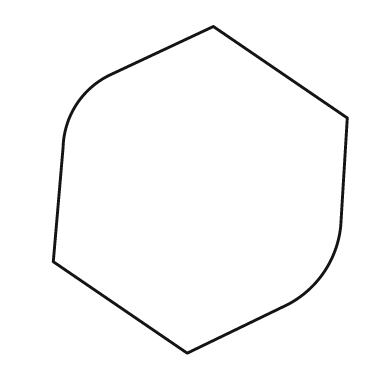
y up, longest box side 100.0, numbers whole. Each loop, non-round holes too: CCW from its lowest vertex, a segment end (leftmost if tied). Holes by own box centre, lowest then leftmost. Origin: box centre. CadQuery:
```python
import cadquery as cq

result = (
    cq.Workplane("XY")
    .moveTo(-4.0, -50.0)
    .lineTo(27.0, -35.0)
    .threePointArc((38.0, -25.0), (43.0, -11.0))
    .lineTo(45.0, 22.0)
    .lineTo(4.0, 50.0)
    .lineTo(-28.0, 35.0)
    .threePointArc((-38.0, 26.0), (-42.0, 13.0))
    .lineTo(-45.0, -22.0)
    .close()
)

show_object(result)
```